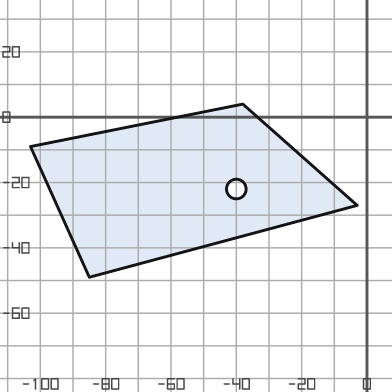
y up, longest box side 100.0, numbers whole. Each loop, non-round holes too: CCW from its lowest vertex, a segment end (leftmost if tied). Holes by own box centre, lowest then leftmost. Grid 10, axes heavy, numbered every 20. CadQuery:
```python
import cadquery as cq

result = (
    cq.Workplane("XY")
    .moveTo(-85.0, -49.0)
    .lineTo(-3.0, -27.0)
    .lineTo(-38.0, 4.0)
    .lineTo(-103.0, -9.0)
    .close()
    .moveTo(-40.0, -22.0)
    .circle(3.0)
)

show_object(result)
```